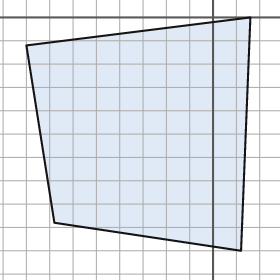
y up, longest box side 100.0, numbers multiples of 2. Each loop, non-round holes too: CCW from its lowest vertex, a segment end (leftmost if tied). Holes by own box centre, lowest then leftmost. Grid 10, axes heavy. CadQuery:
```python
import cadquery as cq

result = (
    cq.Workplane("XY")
    .moveTo(12.0, -100.0)
    .lineTo(16.0, 0.0)
    .lineTo(-80.0, -12.0)
    .lineTo(-68.0, -88.0)
    .close()
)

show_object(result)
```